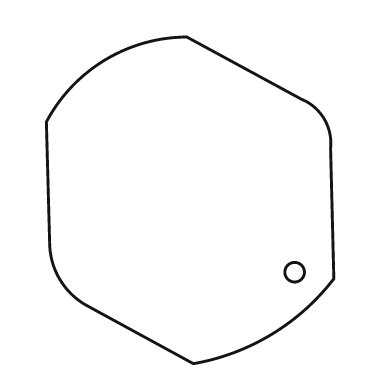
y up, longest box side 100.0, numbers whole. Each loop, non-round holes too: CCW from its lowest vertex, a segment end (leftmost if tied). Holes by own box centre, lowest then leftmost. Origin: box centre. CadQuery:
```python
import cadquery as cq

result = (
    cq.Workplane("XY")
    .moveTo(1.0, -50.0)
    .threePointArc((25.0, -41.0), (44.0, -24.0))
    .lineTo(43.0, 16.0)
    .threePointArc((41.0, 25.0), (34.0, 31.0))
    .lineTo(-1.0, 50.0)
    .threePointArc((-26.0, 43.0), (-44.0, 24.0))
    .lineTo(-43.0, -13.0)
    .threePointArc((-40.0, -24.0), (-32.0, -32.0))
    .close()
    .moveTo(32.0, -22.0)
    .circle(3.0)
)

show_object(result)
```